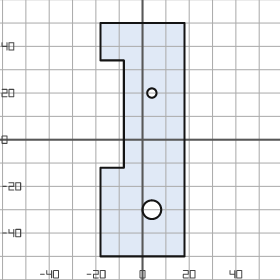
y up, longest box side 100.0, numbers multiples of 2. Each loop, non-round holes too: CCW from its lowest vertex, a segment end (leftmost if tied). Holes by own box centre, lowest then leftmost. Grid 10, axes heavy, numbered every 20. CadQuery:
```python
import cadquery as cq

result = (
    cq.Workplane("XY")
    .moveTo(-18.0, -50.0)
    .lineTo(18.0, -50.0)
    .lineTo(18.0, 50.0)
    .lineTo(-18.0, 50.0)
    .lineTo(-18.0, 34.0)
    .lineTo(-8.0, 34.0)
    .lineTo(-8.0, -12.0)
    .lineTo(-18.0, -12.0)
    .close()
    .moveTo(4.0, -30.0)
    .circle(4.0)
    .moveTo(4.0, 20.0)
    .circle(2.0)
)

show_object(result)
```